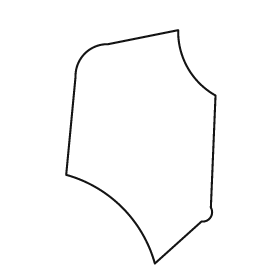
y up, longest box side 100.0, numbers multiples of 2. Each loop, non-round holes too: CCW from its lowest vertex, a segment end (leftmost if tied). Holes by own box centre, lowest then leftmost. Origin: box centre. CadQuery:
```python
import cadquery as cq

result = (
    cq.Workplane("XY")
    .moveTo(6.0, -50.0)
    .lineTo(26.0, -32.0)
    .threePointArc((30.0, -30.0), (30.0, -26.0))
    .lineTo(32.0, 22.0)
    .threePointArc((20.0, 34.0), (16.0, 50.0))
    .lineTo(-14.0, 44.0)
    .threePointArc((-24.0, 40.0), (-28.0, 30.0))
    .lineTo(-32.0, -12.0)
    .threePointArc((-8.0, -26.0), (6.0, -50.0))
    .close()
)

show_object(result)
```